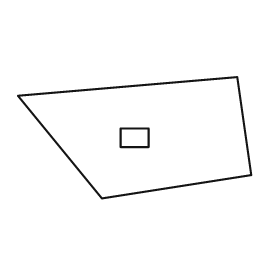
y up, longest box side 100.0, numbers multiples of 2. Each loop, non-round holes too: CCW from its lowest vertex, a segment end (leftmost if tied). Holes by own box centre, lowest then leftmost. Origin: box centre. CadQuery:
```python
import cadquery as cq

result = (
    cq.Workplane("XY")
    .moveTo(-14.0, -26.0)
    .lineTo(50.0, -16.0)
    .lineTo(44.0, 26.0)
    .lineTo(-50.0, 18.0)
    .close()
    .moveTo(-6.0, -4.0)
    .lineTo(6.0, -4.0)
    .lineTo(6.0, 4.0)
    .lineTo(-6.0, 4.0)
    .close()
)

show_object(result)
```